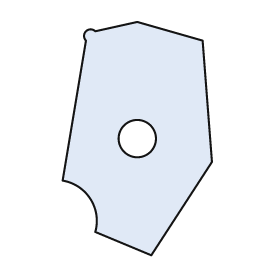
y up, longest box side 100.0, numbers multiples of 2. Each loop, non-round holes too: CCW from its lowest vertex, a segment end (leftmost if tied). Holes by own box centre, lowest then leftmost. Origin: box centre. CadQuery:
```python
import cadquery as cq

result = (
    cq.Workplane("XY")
    .moveTo(6.0, -50.0)
    .lineTo(32.0, -10.0)
    .lineTo(28.0, 42.0)
    .lineTo(0.0, 50.0)
    .lineTo(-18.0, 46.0)
    .threePointArc((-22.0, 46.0), (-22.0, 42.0))
    .lineTo(-32.0, -18.0)
    .threePointArc((-20.0, -26.0), (-18.0, -40.0))
    .close()
    .moveTo(0.0, 0.0)
    .circle(8.0)
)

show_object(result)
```